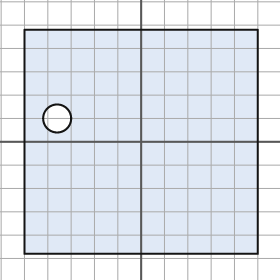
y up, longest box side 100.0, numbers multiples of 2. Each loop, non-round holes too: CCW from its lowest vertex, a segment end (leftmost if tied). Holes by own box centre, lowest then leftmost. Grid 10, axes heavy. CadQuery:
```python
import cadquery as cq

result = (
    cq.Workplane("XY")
    .moveTo(-50.0, -48.0)
    .lineTo(50.0, -48.0)
    .lineTo(50.0, 48.0)
    .lineTo(-50.0, 48.0)
    .close()
    .moveTo(-36.0, 10.0)
    .circle(6.0)
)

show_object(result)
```